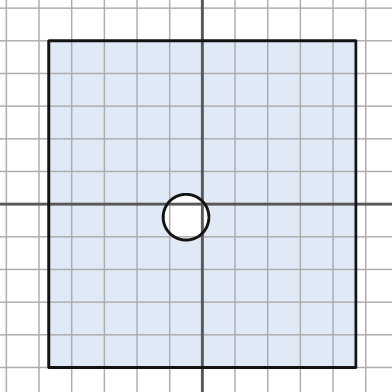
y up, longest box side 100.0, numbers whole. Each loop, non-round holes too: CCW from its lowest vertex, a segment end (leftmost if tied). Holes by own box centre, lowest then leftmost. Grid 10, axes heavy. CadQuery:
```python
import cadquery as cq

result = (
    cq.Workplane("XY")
    .moveTo(-47.0, -50.0)
    .lineTo(47.0, -50.0)
    .lineTo(47.0, 50.0)
    .lineTo(-47.0, 50.0)
    .close()
    .moveTo(-5.0, -4.0)
    .circle(7.0)
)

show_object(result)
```